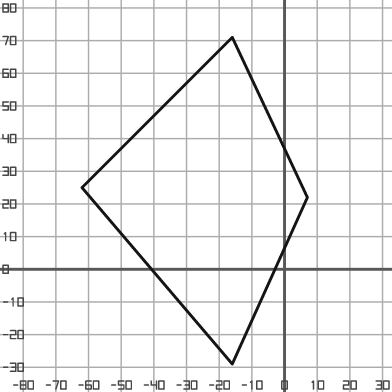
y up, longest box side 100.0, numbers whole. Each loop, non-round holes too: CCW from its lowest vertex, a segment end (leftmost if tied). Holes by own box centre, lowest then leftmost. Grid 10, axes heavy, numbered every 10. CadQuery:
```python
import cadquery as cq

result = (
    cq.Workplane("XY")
    .moveTo(-16.0, -29.0)
    .lineTo(7.0, 22.0)
    .lineTo(-16.0, 71.0)
    .lineTo(-62.0, 25.0)
    .close()
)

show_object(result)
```